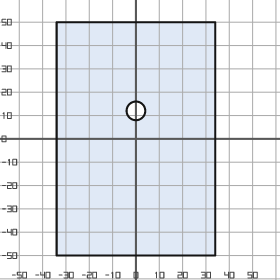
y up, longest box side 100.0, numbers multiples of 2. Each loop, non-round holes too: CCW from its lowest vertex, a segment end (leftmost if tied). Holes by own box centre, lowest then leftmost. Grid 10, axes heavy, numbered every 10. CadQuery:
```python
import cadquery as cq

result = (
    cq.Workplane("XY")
    .moveTo(-34.0, -50.0)
    .lineTo(34.0, -50.0)
    .lineTo(34.0, 50.0)
    .lineTo(-34.0, 50.0)
    .close()
    .moveTo(0.0, 12.0)
    .circle(4.0)
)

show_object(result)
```